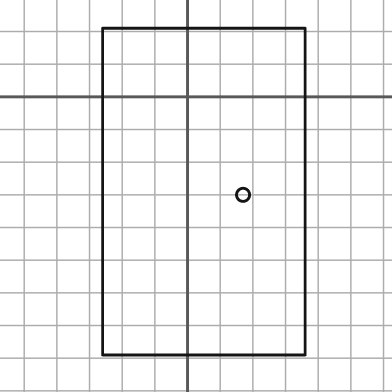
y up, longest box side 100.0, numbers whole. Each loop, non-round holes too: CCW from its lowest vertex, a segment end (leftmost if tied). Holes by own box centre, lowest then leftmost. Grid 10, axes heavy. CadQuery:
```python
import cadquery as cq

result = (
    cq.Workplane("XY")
    .moveTo(-26.0, -79.0)
    .lineTo(36.0, -79.0)
    .lineTo(36.0, 21.0)
    .lineTo(-26.0, 21.0)
    .close()
    .moveTo(17.0, -30.0)
    .circle(2.0)
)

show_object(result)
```